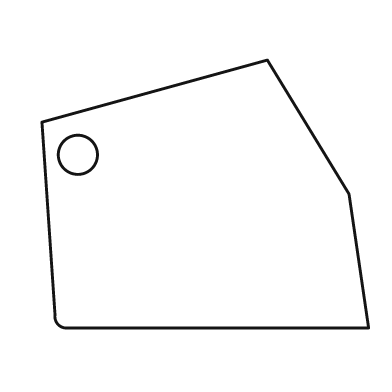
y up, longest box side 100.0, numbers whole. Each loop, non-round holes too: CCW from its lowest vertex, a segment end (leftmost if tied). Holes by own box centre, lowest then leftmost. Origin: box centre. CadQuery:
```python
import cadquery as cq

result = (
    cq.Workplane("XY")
    .moveTo(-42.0, -41.0)
    .lineTo(50.0, -41.0)
    .lineTo(44.0, 0.0)
    .lineTo(19.0, 41.0)
    .lineTo(-50.0, 22.0)
    .lineTo(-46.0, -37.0)
    .threePointArc((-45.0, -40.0), (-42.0, -41.0))
    .close()
    .moveTo(-39.0, 12.0)
    .circle(6.0)
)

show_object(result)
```